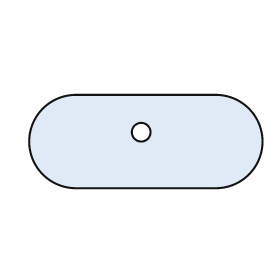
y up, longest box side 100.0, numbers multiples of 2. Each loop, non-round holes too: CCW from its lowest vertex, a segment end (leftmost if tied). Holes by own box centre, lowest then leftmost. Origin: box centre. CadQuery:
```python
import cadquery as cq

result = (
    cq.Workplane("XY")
    .moveTo(-30.0, -20.0)
    .lineTo(30.0, -20.0)
    .threePointArc((50.0, 0.0), (30.0, 20.0))
    .lineTo(-30.0, 20.0)
    .threePointArc((-50.0, 0.0), (-30.0, -20.0))
    .close()
    .moveTo(-2.0, 4.0)
    .circle(4.0)
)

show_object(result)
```